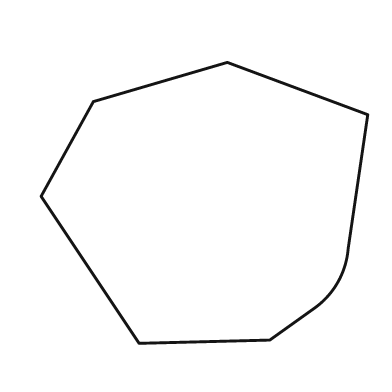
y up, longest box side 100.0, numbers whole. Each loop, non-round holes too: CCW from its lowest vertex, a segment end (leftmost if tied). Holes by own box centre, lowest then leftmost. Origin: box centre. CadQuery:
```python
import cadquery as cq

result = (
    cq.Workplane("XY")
    .moveTo(-20.0, -43.0)
    .lineTo(20.0, -42.0)
    .lineTo(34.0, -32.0)
    .threePointArc((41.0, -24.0), (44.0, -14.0))
    .lineTo(50.0, 27.0)
    .lineTo(7.0, 43.0)
    .lineTo(-34.0, 31.0)
    .lineTo(-50.0, 2.0)
    .close()
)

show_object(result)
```